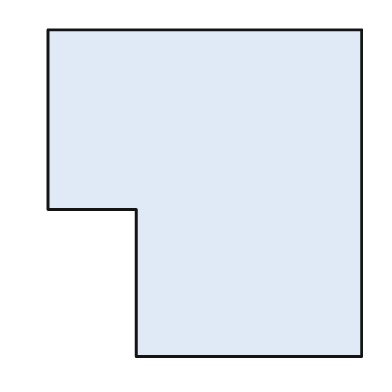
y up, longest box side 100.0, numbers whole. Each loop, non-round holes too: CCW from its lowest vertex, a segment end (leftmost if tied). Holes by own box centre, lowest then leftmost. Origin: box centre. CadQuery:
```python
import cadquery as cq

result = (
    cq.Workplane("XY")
    .moveTo(-21.0, -50.0)
    .lineTo(48.0, -50.0)
    .lineTo(48.0, 50.0)
    .lineTo(-48.0, 50.0)
    .lineTo(-48.0, -5.0)
    .lineTo(-21.0, -5.0)
    .close()
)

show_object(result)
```